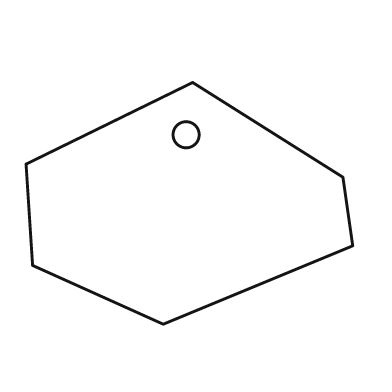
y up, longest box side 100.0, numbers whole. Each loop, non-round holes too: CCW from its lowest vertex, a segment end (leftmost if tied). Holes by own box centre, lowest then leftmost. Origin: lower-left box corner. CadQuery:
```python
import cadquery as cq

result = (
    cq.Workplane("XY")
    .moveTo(42.0, 0.0)
    .lineTo(100.0, 24.0)
    .lineTo(97.0, 45.0)
    .lineTo(51.0, 74.0)
    .lineTo(0.0, 49.0)
    .lineTo(2.0, 18.0)
    .close()
    .moveTo(49.0, 58.0)
    .circle(4.0)
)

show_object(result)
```